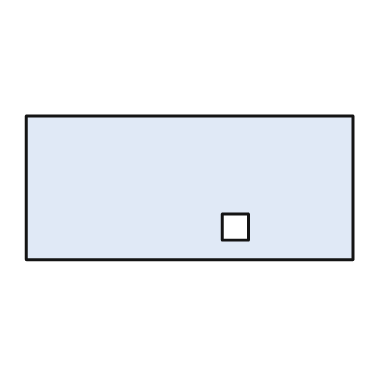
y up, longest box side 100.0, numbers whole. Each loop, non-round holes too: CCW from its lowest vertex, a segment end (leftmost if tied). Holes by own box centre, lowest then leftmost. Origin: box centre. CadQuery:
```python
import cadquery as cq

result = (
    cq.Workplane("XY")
    .moveTo(-50.0, -22.0)
    .lineTo(50.0, -22.0)
    .lineTo(50.0, 22.0)
    .lineTo(-50.0, 22.0)
    .close()
    .moveTo(10.0, -16.0)
    .lineTo(18.0, -16.0)
    .lineTo(18.0, -8.0)
    .lineTo(10.0, -8.0)
    .close()
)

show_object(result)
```